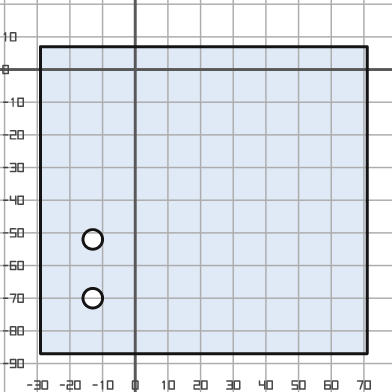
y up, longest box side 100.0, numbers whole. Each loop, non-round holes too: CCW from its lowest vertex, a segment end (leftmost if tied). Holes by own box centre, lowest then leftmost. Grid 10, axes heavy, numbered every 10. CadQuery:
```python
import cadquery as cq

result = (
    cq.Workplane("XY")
    .moveTo(-29.0, -87.0)
    .lineTo(71.0, -87.0)
    .lineTo(71.0, 7.0)
    .lineTo(-29.0, 7.0)
    .close()
    .moveTo(-13.0, -70.0)
    .circle(3.0)
    .moveTo(-13.0, -52.0)
    .circle(3.0)
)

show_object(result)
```